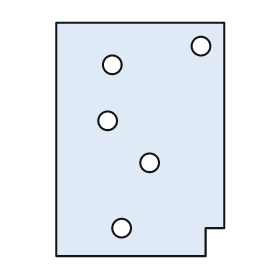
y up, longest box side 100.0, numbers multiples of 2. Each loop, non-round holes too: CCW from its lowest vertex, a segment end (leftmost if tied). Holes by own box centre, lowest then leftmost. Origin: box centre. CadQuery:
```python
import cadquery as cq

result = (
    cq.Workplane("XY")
    .moveTo(-36.0, -50.0)
    .lineTo(28.0, -50.0)
    .lineTo(28.0, -38.0)
    .lineTo(36.0, -38.0)
    .lineTo(36.0, 50.0)
    .lineTo(-36.0, 50.0)
    .close()
    .moveTo(-8.0, -38.0)
    .circle(4.0)
    .moveTo(4.0, -10.0)
    .circle(4.0)
    .moveTo(-14.0, 8.0)
    .circle(4.0)
    .moveTo(-12.0, 32.0)
    .circle(4.0)
    .moveTo(26.0, 40.0)
    .circle(4.0)
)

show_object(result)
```